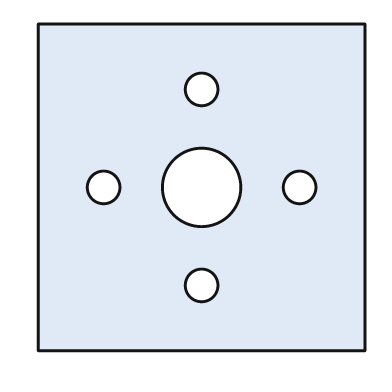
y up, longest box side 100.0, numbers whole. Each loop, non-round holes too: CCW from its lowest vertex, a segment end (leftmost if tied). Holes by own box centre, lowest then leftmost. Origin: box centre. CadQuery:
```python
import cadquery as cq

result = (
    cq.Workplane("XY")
    .moveTo(-50.0, -50.0)
    .lineTo(50.0, -50.0)
    .lineTo(50.0, 50.0)
    .lineTo(-50.0, 50.0)
    .close()
    .moveTo(0.0, -30.0)
    .circle(5.0)
    .moveTo(-30.0, 0.0)
    .circle(5.0)
    .moveTo(0.0, 0.0)
    .circle(12.0)
    .moveTo(30.0, 0.0)
    .circle(5.0)
    .moveTo(0.0, 30.0)
    .circle(5.0)
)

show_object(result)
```